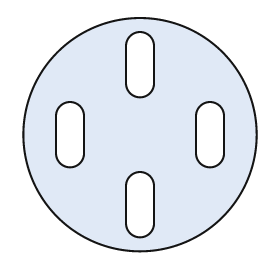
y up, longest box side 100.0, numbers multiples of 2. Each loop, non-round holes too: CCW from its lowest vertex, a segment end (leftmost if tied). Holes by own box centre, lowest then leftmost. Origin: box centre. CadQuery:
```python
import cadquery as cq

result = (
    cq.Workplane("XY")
    .moveTo(0.0, 0.0)
    .circle(50.0)
    .moveTo(-6.0, -38.0)
    .threePointArc((0.0, -44.0), (6.0, -38.0))
    .lineTo(6.0, -22.0)
    .threePointArc((0.0, -16.0), (-6.0, -22.0))
    .close()
    .moveTo(-36.0, -8.0)
    .threePointArc((-30.0, -14.0), (-24.0, -8.0))
    .lineTo(-24.0, 8.0)
    .threePointArc((-30.0, 14.0), (-36.0, 8.0))
    .close()
    .moveTo(24.0, -8.0)
    .threePointArc((30.0, -14.0), (36.0, -8.0))
    .lineTo(36.0, 8.0)
    .threePointArc((30.0, 14.0), (24.0, 8.0))
    .close()
    .moveTo(-6.0, 22.0)
    .threePointArc((0.0, 16.0), (6.0, 22.0))
    .lineTo(6.0, 38.0)
    .threePointArc((0.0, 44.0), (-6.0, 38.0))
    .close()
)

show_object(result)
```